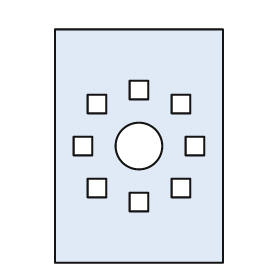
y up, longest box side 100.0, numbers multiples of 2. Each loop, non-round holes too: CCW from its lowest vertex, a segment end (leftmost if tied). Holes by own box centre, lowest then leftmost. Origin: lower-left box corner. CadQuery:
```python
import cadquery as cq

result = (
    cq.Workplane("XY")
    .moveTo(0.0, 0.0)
    .lineTo(72.0, 0.0)
    .lineTo(72.0, 100.0)
    .lineTo(0.0, 100.0)
    .close()
    .moveTo(32.0, 22.0)
    .lineTo(40.0, 22.0)
    .lineTo(40.0, 30.0)
    .lineTo(32.0, 30.0)
    .close()
    .moveTo(14.0, 28.0)
    .lineTo(22.0, 28.0)
    .lineTo(22.0, 36.0)
    .lineTo(14.0, 36.0)
    .close()
    .moveTo(50.0, 28.0)
    .lineTo(58.0, 28.0)
    .lineTo(58.0, 36.0)
    .lineTo(50.0, 36.0)
    .close()
    .moveTo(8.0, 46.0)
    .lineTo(16.0, 46.0)
    .lineTo(16.0, 54.0)
    .lineTo(8.0, 54.0)
    .close()
    .moveTo(36.0, 50.0)
    .circle(10.0)
    .moveTo(56.0, 46.0)
    .lineTo(64.0, 46.0)
    .lineTo(64.0, 54.0)
    .lineTo(56.0, 54.0)
    .close()
    .moveTo(14.0, 64.0)
    .lineTo(22.0, 64.0)
    .lineTo(22.0, 72.0)
    .lineTo(14.0, 72.0)
    .close()
    .moveTo(50.0, 64.0)
    .lineTo(58.0, 64.0)
    .lineTo(58.0, 72.0)
    .lineTo(50.0, 72.0)
    .close()
    .moveTo(32.0, 70.0)
    .lineTo(40.0, 70.0)
    .lineTo(40.0, 78.0)
    .lineTo(32.0, 78.0)
    .close()
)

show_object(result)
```